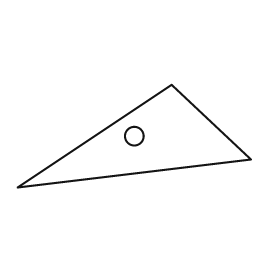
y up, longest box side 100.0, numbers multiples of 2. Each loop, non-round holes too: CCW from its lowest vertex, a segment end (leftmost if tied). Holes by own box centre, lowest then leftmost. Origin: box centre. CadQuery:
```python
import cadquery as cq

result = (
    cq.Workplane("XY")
    .moveTo(-50.0, -22.0)
    .lineTo(50.0, -10.0)
    .lineTo(16.0, 22.0)
    .close()
    .moveTo(0.0, 0.0)
    .circle(4.0)
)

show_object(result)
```